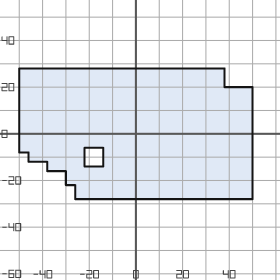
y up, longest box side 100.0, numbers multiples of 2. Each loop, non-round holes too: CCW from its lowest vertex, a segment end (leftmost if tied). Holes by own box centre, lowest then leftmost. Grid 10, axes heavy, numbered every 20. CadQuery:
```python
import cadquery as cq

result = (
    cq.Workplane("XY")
    .moveTo(-26.0, -28.0)
    .lineTo(50.0, -28.0)
    .lineTo(50.0, 20.0)
    .lineTo(38.0, 20.0)
    .lineTo(38.0, 28.0)
    .lineTo(-50.0, 28.0)
    .lineTo(-50.0, -8.0)
    .lineTo(-46.0, -8.0)
    .lineTo(-46.0, -12.0)
    .lineTo(-38.0, -12.0)
    .lineTo(-38.0, -16.0)
    .lineTo(-30.0, -16.0)
    .lineTo(-30.0, -22.0)
    .lineTo(-26.0, -22.0)
    .close()
    .moveTo(-22.0, -14.0)
    .lineTo(-14.0, -14.0)
    .lineTo(-14.0, -6.0)
    .lineTo(-22.0, -6.0)
    .close()
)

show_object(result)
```